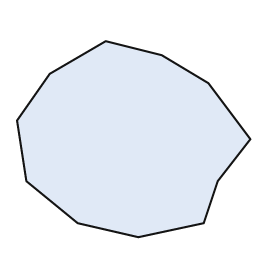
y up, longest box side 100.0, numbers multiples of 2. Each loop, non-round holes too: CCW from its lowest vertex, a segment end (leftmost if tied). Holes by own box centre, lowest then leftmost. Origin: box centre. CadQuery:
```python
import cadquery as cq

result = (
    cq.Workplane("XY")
    .moveTo(2.0, -42.0)
    .lineTo(30.0, -36.0)
    .lineTo(36.0, -18.0)
    .lineTo(50.0, 0.0)
    .lineTo(32.0, 24.0)
    .lineTo(12.0, 36.0)
    .lineTo(-12.0, 42.0)
    .lineTo(-36.0, 28.0)
    .lineTo(-50.0, 8.0)
    .lineTo(-46.0, -18.0)
    .lineTo(-24.0, -36.0)
    .close()
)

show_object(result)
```